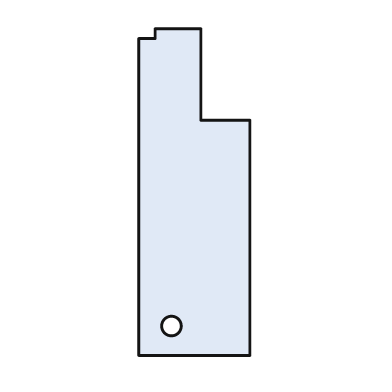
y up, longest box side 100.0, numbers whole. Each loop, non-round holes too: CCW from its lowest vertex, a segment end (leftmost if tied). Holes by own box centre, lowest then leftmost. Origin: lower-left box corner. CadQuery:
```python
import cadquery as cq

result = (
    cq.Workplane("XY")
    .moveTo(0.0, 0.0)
    .lineTo(34.0, 0.0)
    .lineTo(34.0, 72.0)
    .lineTo(19.0, 72.0)
    .lineTo(19.0, 100.0)
    .lineTo(5.0, 100.0)
    .lineTo(5.0, 97.0)
    .lineTo(0.0, 97.0)
    .close()
    .moveTo(10.0, 9.0)
    .circle(3.0)
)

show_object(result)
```